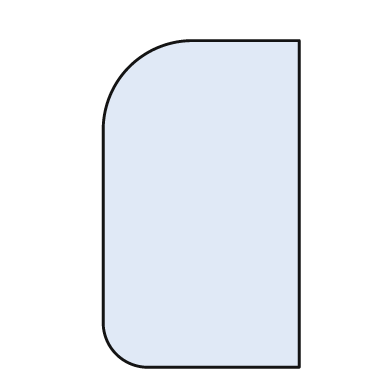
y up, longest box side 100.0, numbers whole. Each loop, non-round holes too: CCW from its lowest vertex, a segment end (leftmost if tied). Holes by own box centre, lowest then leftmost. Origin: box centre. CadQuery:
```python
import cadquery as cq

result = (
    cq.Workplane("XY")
    .moveTo(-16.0, -50.0)
    .lineTo(30.0, -50.0)
    .lineTo(30.0, 50.0)
    .lineTo(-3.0, 50.0)
    .threePointArc((-22.0, 42.0), (-30.0, 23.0))
    .lineTo(-30.0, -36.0)
    .threePointArc((-26.0, -46.0), (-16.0, -50.0))
    .close()
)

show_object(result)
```